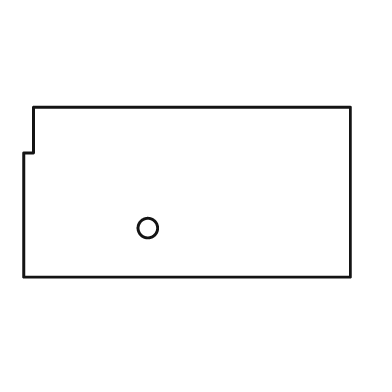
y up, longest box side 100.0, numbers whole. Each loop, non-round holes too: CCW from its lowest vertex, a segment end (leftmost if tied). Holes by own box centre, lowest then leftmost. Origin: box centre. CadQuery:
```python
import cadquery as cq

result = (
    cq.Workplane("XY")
    .moveTo(-50.0, -26.0)
    .lineTo(50.0, -26.0)
    .lineTo(50.0, 26.0)
    .lineTo(-47.0, 26.0)
    .lineTo(-47.0, 12.0)
    .lineTo(-50.0, 12.0)
    .close()
    .moveTo(-12.0, -11.0)
    .circle(3.0)
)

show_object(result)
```